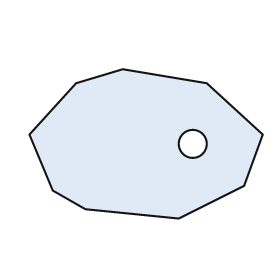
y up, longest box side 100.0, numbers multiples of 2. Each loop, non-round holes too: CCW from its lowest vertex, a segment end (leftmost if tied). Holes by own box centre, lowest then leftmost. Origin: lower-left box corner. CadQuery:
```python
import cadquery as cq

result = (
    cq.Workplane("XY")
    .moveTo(64.0, 0.0)
    .lineTo(92.0, 14.0)
    .lineTo(100.0, 36.0)
    .lineTo(76.0, 58.0)
    .lineTo(40.0, 64.0)
    .lineTo(20.0, 58.0)
    .lineTo(0.0, 36.0)
    .lineTo(10.0, 12.0)
    .lineTo(24.0, 4.0)
    .close()
    .moveTo(70.0, 32.0)
    .circle(6.0)
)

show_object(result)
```